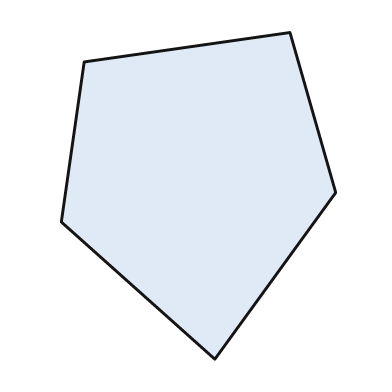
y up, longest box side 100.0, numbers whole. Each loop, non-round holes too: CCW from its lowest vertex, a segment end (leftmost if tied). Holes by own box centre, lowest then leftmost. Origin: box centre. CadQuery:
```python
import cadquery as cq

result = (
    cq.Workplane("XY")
    .moveTo(5.0, -50.0)
    .lineTo(42.0, 1.0)
    .lineTo(28.0, 50.0)
    .lineTo(-35.0, 41.0)
    .lineTo(-42.0, -8.0)
    .close()
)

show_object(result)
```